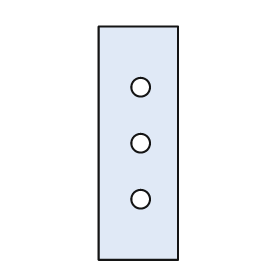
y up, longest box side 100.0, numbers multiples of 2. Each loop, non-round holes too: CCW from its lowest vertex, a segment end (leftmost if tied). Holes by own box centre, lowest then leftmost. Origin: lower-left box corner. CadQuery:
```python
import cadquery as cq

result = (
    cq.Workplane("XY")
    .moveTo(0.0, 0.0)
    .lineTo(34.0, 0.0)
    .lineTo(34.0, 100.0)
    .lineTo(0.0, 100.0)
    .close()
    .moveTo(18.0, 26.0)
    .circle(4.0)
    .moveTo(18.0, 50.0)
    .circle(4.0)
    .moveTo(18.0, 74.0)
    .circle(4.0)
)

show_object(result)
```